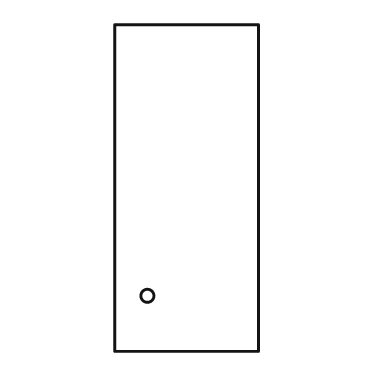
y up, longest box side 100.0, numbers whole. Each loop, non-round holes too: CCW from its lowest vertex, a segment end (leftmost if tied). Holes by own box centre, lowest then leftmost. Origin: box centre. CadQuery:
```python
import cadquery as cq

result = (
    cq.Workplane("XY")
    .moveTo(-22.0, -50.0)
    .lineTo(22.0, -50.0)
    .lineTo(22.0, 50.0)
    .lineTo(-22.0, 50.0)
    .close()
    .moveTo(-12.0, -33.0)
    .circle(2.0)
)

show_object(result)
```